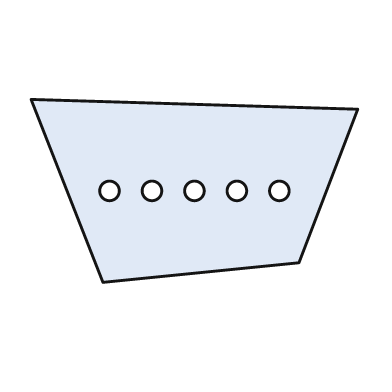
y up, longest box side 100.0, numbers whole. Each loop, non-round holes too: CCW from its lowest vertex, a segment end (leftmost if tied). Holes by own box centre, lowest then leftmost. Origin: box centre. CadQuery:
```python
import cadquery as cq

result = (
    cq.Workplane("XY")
    .moveTo(-28.0, -28.0)
    .lineTo(32.0, -22.0)
    .lineTo(50.0, 25.0)
    .lineTo(-50.0, 28.0)
    .close()
    .moveTo(-26.0, 0.0)
    .circle(3.0)
    .moveTo(-13.0, 0.0)
    .circle(3.0)
    .moveTo(0.0, 0.0)
    .circle(3.0)
    .moveTo(13.0, 0.0)
    .circle(3.0)
    .moveTo(26.0, 0.0)
    .circle(3.0)
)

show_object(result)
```